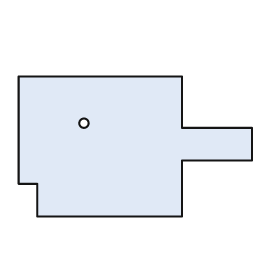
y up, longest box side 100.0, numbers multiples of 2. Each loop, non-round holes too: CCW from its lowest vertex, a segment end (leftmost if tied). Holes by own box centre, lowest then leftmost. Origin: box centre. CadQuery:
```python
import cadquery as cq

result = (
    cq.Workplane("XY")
    .moveTo(-42.0, -30.0)
    .lineTo(20.0, -30.0)
    .lineTo(20.0, -6.0)
    .lineTo(50.0, -6.0)
    .lineTo(50.0, 8.0)
    .lineTo(20.0, 8.0)
    .lineTo(20.0, 30.0)
    .lineTo(-50.0, 30.0)
    .lineTo(-50.0, -16.0)
    .lineTo(-42.0, -16.0)
    .close()
    .moveTo(-22.0, 10.0)
    .circle(2.0)
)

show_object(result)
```